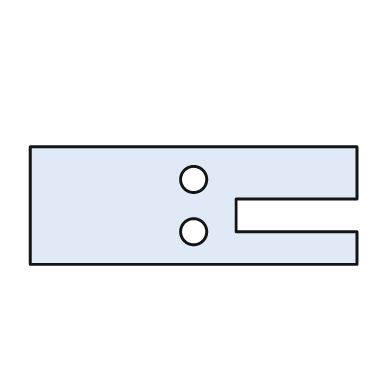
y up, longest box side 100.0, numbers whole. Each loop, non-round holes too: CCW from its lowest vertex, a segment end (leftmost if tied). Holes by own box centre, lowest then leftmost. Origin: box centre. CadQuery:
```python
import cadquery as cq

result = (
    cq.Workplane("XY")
    .moveTo(-50.0, -18.0)
    .lineTo(50.0, -18.0)
    .lineTo(50.0, -8.0)
    .lineTo(13.0, -8.0)
    .lineTo(13.0, 2.0)
    .lineTo(50.0, 2.0)
    .lineTo(50.0, 18.0)
    .lineTo(-50.0, 18.0)
    .close()
    .moveTo(0.0, -8.0)
    .circle(4.0)
    .moveTo(0.0, 8.0)
    .circle(4.0)
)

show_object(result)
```